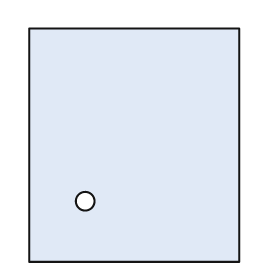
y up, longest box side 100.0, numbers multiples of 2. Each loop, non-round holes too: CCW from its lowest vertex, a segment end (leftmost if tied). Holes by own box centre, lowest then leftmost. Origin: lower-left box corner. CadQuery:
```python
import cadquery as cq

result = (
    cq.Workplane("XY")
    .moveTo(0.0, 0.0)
    .lineTo(90.0, 0.0)
    .lineTo(90.0, 100.0)
    .lineTo(0.0, 100.0)
    .close()
    .moveTo(24.0, 26.0)
    .circle(4.0)
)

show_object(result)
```